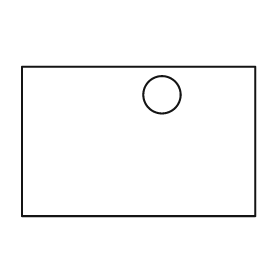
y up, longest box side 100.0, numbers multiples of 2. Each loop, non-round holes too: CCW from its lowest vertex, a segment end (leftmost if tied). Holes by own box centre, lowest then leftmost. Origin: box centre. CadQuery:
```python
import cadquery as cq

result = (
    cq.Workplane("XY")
    .moveTo(-50.0, -32.0)
    .lineTo(50.0, -32.0)
    .lineTo(50.0, 32.0)
    .lineTo(-50.0, 32.0)
    .close()
    .moveTo(10.0, 20.0)
    .circle(8.0)
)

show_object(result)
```